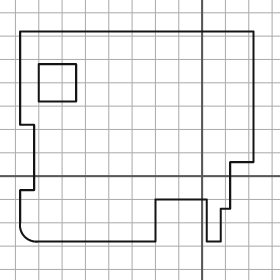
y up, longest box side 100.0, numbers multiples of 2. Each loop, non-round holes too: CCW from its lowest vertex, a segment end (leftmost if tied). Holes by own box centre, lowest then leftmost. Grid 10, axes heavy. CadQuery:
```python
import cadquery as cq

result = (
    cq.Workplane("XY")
    .moveTo(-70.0, -28.0)
    .lineTo(-20.0, -28.0)
    .lineTo(-20.0, -10.0)
    .lineTo(2.0, -10.0)
    .lineTo(2.0, -28.0)
    .lineTo(8.0, -28.0)
    .lineTo(8.0, -14.0)
    .lineTo(12.0, -14.0)
    .lineTo(12.0, 6.0)
    .lineTo(22.0, 6.0)
    .lineTo(22.0, 62.0)
    .lineTo(-78.0, 62.0)
    .lineTo(-78.0, 22.0)
    .lineTo(-72.0, 22.0)
    .lineTo(-72.0, -6.0)
    .lineTo(-78.0, -6.0)
    .lineTo(-78.0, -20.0)
    .threePointArc((-76.0, -26.0), (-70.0, -28.0))
    .close()
    .moveTo(-70.0, 32.0)
    .lineTo(-54.0, 32.0)
    .lineTo(-54.0, 48.0)
    .lineTo(-70.0, 48.0)
    .close()
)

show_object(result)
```